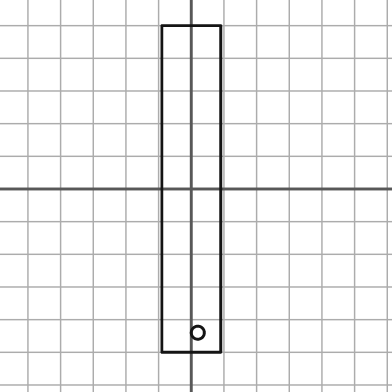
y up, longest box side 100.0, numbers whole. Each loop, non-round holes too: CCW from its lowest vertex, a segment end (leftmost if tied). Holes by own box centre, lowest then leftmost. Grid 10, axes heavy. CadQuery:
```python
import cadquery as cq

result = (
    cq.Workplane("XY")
    .moveTo(-9.0, -50.0)
    .lineTo(9.0, -50.0)
    .lineTo(9.0, 50.0)
    .lineTo(-9.0, 50.0)
    .close()
    .moveTo(2.0, -44.0)
    .circle(2.0)
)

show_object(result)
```